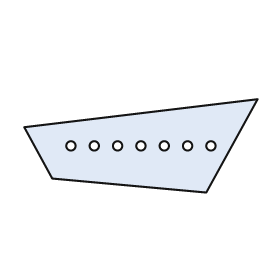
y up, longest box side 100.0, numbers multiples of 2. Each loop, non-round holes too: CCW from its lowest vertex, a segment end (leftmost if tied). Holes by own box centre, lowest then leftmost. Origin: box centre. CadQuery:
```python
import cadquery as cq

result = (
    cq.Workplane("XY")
    .moveTo(28.0, -20.0)
    .lineTo(50.0, 20.0)
    .lineTo(-50.0, 8.0)
    .lineTo(-38.0, -14.0)
    .close()
    .moveTo(-30.0, 0.0)
    .circle(2.0)
    .moveTo(-20.0, 0.0)
    .circle(2.0)
    .moveTo(-10.0, 0.0)
    .circle(2.0)
    .moveTo(0.0, 0.0)
    .circle(2.0)
    .moveTo(10.0, 0.0)
    .circle(2.0)
    .moveTo(20.0, 0.0)
    .circle(2.0)
    .moveTo(30.0, 0.0)
    .circle(2.0)
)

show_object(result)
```